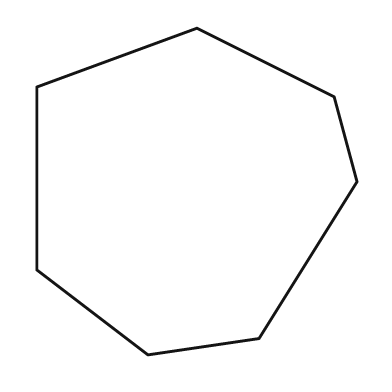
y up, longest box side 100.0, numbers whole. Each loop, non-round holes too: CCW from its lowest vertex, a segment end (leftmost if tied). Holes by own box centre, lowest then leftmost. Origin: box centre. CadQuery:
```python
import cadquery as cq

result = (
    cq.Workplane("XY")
    .moveTo(-15.0, -50.0)
    .lineTo(19.0, -45.0)
    .lineTo(49.0, 3.0)
    .lineTo(42.0, 29.0)
    .lineTo(0.0, 50.0)
    .lineTo(-49.0, 32.0)
    .lineTo(-49.0, -24.0)
    .close()
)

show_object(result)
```